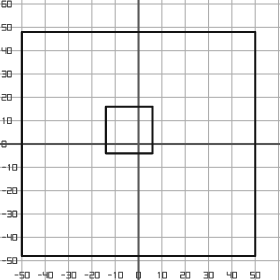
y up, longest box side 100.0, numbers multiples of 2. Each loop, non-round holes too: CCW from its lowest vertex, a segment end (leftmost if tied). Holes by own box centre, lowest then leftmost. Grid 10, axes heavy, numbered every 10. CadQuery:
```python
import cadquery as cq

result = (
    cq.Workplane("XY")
    .moveTo(-50.0, -48.0)
    .lineTo(50.0, -48.0)
    .lineTo(50.0, 48.0)
    .lineTo(-50.0, 48.0)
    .close()
    .moveTo(-14.0, -4.0)
    .lineTo(6.0, -4.0)
    .lineTo(6.0, 16.0)
    .lineTo(-14.0, 16.0)
    .close()
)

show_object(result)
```